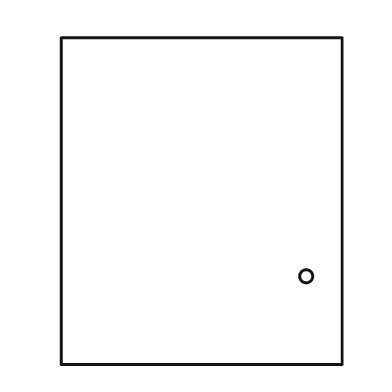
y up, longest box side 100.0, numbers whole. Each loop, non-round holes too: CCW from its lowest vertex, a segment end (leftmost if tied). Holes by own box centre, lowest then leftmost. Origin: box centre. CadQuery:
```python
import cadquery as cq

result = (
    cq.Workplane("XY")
    .moveTo(-43.0, -50.0)
    .lineTo(43.0, -50.0)
    .lineTo(43.0, 50.0)
    .lineTo(-43.0, 50.0)
    .close()
    .moveTo(32.0, -23.0)
    .circle(2.0)
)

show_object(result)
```